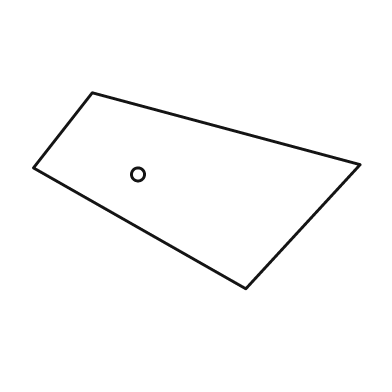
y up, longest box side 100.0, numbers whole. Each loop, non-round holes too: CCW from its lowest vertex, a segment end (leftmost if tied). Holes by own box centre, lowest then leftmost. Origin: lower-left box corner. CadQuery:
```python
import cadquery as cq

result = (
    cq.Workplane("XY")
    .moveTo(65.0, 0.0)
    .lineTo(100.0, 38.0)
    .lineTo(18.0, 60.0)
    .lineTo(0.0, 37.0)
    .close()
    .moveTo(32.0, 35.0)
    .circle(2.0)
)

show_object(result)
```